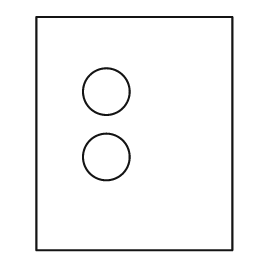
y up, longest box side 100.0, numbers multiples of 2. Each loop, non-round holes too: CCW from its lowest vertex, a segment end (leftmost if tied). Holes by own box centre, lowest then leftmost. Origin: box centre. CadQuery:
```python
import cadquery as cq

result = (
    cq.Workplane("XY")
    .moveTo(-42.0, -50.0)
    .lineTo(42.0, -50.0)
    .lineTo(42.0, 50.0)
    .lineTo(-42.0, 50.0)
    .close()
    .moveTo(-12.0, -10.0)
    .circle(10.0)
    .moveTo(-12.0, 18.0)
    .circle(10.0)
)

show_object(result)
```